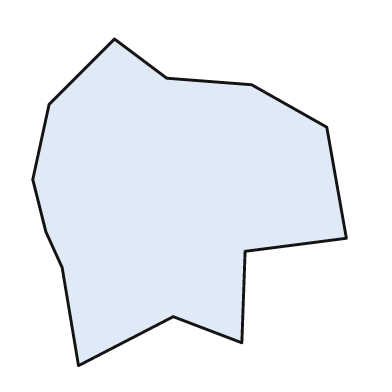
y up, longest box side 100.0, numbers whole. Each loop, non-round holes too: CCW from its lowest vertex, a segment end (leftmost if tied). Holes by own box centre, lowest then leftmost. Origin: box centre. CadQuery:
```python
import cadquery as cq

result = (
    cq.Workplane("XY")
    .moveTo(-34.0, -50.0)
    .lineTo(-5.0, -35.0)
    .lineTo(16.0, -43.0)
    .lineTo(17.0, -15.0)
    .lineTo(48.0, -11.0)
    .lineTo(42.0, 23.0)
    .lineTo(19.0, 36.0)
    .lineTo(-7.0, 38.0)
    .lineTo(-23.0, 50.0)
    .lineTo(-43.0, 30.0)
    .lineTo(-48.0, 7.0)
    .lineTo(-44.0, -9.0)
    .lineTo(-39.0, -20.0)
    .close()
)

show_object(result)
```